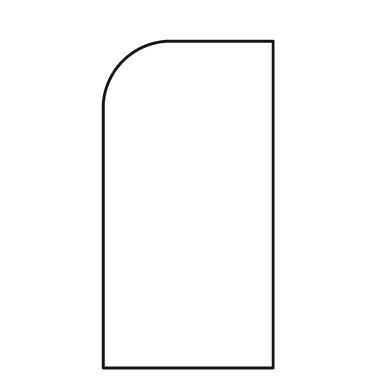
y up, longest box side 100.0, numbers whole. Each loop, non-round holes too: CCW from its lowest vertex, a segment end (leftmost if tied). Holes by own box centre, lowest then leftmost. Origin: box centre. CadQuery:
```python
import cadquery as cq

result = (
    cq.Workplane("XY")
    .moveTo(-26.0, -50.0)
    .lineTo(26.0, -50.0)
    .lineTo(26.0, 50.0)
    .lineTo(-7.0, 50.0)
    .threePointArc((-20.0, 44.0), (-26.0, 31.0))
    .close()
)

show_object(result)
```